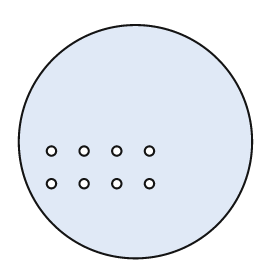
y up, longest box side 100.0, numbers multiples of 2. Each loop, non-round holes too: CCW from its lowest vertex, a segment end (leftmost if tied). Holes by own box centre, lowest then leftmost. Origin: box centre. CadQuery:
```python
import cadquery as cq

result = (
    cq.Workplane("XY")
    .moveTo(0.0, 0.0)
    .circle(50.0)
    .moveTo(-36.0, -18.0)
    .circle(2.0)
    .moveTo(-22.0, -18.0)
    .circle(2.0)
    .moveTo(-8.0, -18.0)
    .circle(2.0)
    .moveTo(6.0, -18.0)
    .circle(2.0)
    .moveTo(-36.0, -4.0)
    .circle(2.0)
    .moveTo(-22.0, -4.0)
    .circle(2.0)
    .moveTo(-8.0, -4.0)
    .circle(2.0)
    .moveTo(6.0, -4.0)
    .circle(2.0)
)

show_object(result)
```